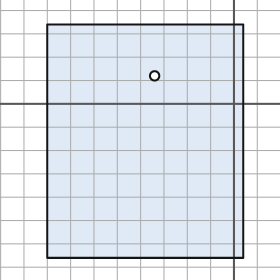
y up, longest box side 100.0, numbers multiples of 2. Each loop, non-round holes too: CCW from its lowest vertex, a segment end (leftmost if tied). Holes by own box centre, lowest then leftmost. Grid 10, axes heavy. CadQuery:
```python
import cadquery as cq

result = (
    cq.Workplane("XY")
    .moveTo(-80.0, -66.0)
    .lineTo(4.0, -66.0)
    .lineTo(4.0, 34.0)
    .lineTo(-80.0, 34.0)
    .close()
    .moveTo(-34.0, 12.0)
    .circle(2.0)
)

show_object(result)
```